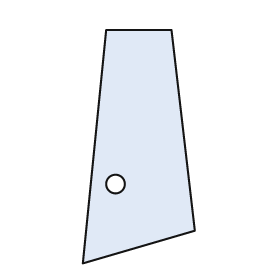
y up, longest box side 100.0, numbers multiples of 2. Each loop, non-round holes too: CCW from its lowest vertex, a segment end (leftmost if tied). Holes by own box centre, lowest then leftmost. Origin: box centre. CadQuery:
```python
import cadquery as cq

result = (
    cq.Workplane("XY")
    .moveTo(-24.0, -50.0)
    .lineTo(24.0, -36.0)
    .lineTo(14.0, 50.0)
    .lineTo(-14.0, 50.0)
    .close()
    .moveTo(-10.0, -16.0)
    .circle(4.0)
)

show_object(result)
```